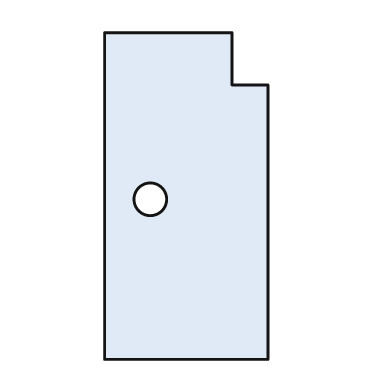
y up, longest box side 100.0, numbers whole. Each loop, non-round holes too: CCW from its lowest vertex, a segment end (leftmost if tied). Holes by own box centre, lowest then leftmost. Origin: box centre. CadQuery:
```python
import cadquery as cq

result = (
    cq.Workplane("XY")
    .moveTo(-25.0, -50.0)
    .lineTo(25.0, -50.0)
    .lineTo(25.0, 34.0)
    .lineTo(14.0, 34.0)
    .lineTo(14.0, 50.0)
    .lineTo(-25.0, 50.0)
    .close()
    .moveTo(-11.0, -1.0)
    .circle(5.0)
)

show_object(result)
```